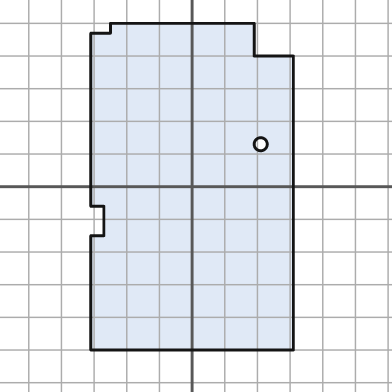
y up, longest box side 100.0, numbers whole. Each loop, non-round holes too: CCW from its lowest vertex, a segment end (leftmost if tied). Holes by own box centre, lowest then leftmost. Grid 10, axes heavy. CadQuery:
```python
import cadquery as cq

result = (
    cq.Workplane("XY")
    .moveTo(-31.0, -50.0)
    .lineTo(31.0, -50.0)
    .lineTo(31.0, 40.0)
    .lineTo(19.0, 40.0)
    .lineTo(19.0, 50.0)
    .lineTo(-25.0, 50.0)
    .lineTo(-25.0, 47.0)
    .lineTo(-31.0, 47.0)
    .lineTo(-31.0, -6.0)
    .lineTo(-27.0, -6.0)
    .lineTo(-27.0, -15.0)
    .lineTo(-31.0, -15.0)
    .close()
    .moveTo(21.0, 13.0)
    .circle(2.0)
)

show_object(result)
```